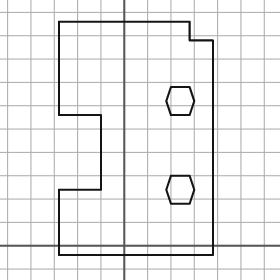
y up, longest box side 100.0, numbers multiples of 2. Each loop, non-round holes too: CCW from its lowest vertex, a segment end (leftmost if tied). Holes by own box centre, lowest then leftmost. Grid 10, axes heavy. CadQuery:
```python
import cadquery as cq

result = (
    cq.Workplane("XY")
    .moveTo(-28.0, -4.0)
    .lineTo(38.0, -4.0)
    .lineTo(38.0, 88.0)
    .lineTo(28.0, 88.0)
    .lineTo(28.0, 96.0)
    .lineTo(-28.0, 96.0)
    .lineTo(-28.0, 56.0)
    .lineTo(-10.0, 56.0)
    .lineTo(-10.0, 24.0)
    .lineTo(-28.0, 24.0)
    .close()
    .moveTo(20.0, 18.0)
    .lineTo(28.0, 18.0)
    .lineTo(30.0, 24.0)
    .lineTo(28.0, 30.0)
    .lineTo(20.0, 30.0)
    .lineTo(18.0, 24.0)
    .close()
    .moveTo(20.0, 56.0)
    .lineTo(28.0, 56.0)
    .lineTo(30.0, 62.0)
    .lineTo(28.0, 68.0)
    .lineTo(20.0, 68.0)
    .lineTo(18.0, 62.0)
    .close()
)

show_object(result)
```